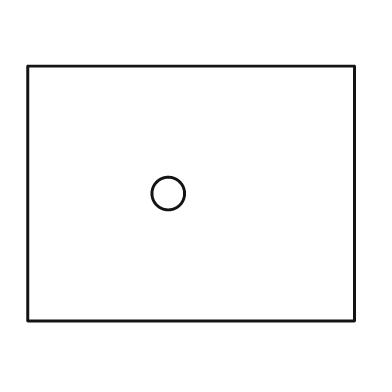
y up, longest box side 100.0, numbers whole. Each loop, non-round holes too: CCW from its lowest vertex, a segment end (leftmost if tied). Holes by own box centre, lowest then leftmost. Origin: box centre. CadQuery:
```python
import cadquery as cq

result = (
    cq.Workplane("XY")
    .moveTo(-50.0, -39.0)
    .lineTo(50.0, -39.0)
    .lineTo(50.0, 39.0)
    .lineTo(-50.0, 39.0)
    .close()
    .moveTo(-7.0, 0.0)
    .circle(5.0)
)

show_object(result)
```